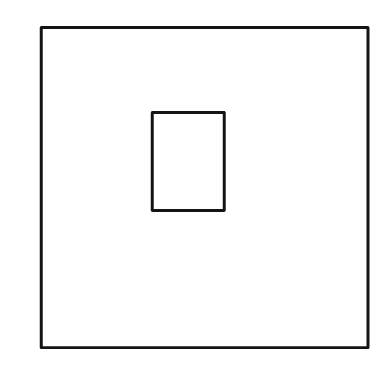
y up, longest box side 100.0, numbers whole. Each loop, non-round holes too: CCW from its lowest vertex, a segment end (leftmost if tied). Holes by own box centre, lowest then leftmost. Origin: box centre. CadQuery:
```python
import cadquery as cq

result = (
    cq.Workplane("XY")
    .moveTo(-50.0, -49.0)
    .lineTo(50.0, -49.0)
    .lineTo(50.0, 49.0)
    .lineTo(-50.0, 49.0)
    .close()
    .moveTo(-16.0, -7.0)
    .lineTo(6.0, -7.0)
    .lineTo(6.0, 23.0)
    .lineTo(-16.0, 23.0)
    .close()
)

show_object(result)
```